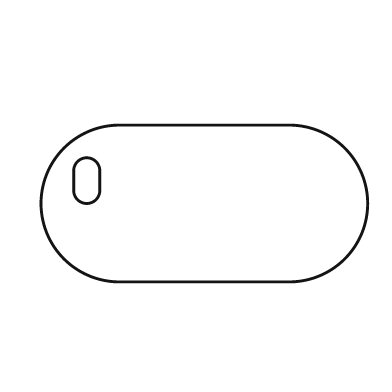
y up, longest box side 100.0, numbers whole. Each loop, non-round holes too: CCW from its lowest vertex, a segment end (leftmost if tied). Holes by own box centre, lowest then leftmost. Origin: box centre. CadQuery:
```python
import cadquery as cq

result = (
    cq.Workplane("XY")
    .moveTo(-26.0, -24.0)
    .lineTo(26.0, -24.0)
    .threePointArc((50.0, 0.0), (26.0, 24.0))
    .lineTo(-26.0, 24.0)
    .threePointArc((-50.0, 0.0), (-26.0, -24.0))
    .close()
    .moveTo(-40.0, 4.0)
    .threePointArc((-36.0, 0.0), (-32.0, 4.0))
    .lineTo(-32.0, 10.0)
    .threePointArc((-36.0, 14.0), (-40.0, 10.0))
    .close()
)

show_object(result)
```